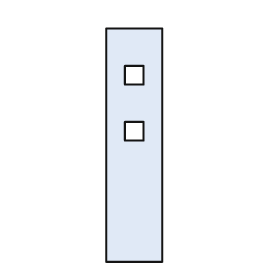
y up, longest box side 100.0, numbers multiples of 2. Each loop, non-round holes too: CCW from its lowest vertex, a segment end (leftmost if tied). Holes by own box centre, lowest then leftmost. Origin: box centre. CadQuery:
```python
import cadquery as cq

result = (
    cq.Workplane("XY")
    .moveTo(-12.0, -50.0)
    .lineTo(12.0, -50.0)
    .lineTo(12.0, 50.0)
    .lineTo(-12.0, 50.0)
    .close()
    .moveTo(-4.0, 2.0)
    .lineTo(4.0, 2.0)
    .lineTo(4.0, 10.0)
    .lineTo(-4.0, 10.0)
    .close()
    .moveTo(-4.0, 26.0)
    .lineTo(4.0, 26.0)
    .lineTo(4.0, 34.0)
    .lineTo(-4.0, 34.0)
    .close()
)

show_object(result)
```